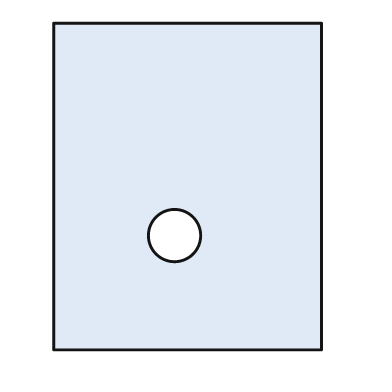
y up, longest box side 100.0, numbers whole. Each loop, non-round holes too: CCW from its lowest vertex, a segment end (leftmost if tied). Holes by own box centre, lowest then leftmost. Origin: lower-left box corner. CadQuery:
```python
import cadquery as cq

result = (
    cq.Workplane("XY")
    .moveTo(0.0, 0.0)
    .lineTo(82.0, 0.0)
    .lineTo(82.0, 100.0)
    .lineTo(0.0, 100.0)
    .close()
    .moveTo(37.0, 35.0)
    .circle(8.0)
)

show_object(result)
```